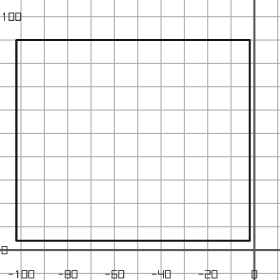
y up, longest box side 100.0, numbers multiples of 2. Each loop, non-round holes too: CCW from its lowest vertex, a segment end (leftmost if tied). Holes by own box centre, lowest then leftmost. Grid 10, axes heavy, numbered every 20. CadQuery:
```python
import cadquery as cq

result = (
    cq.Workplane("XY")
    .moveTo(-102.0, 4.0)
    .lineTo(-2.0, 4.0)
    .lineTo(-2.0, 90.0)
    .lineTo(-102.0, 90.0)
    .close()
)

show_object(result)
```